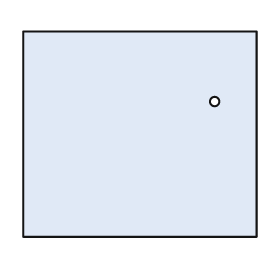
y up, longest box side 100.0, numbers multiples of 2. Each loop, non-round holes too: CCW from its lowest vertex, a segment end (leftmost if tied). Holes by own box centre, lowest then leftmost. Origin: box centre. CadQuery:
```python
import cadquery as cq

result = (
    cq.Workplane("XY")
    .moveTo(-50.0, -44.0)
    .lineTo(50.0, -44.0)
    .lineTo(50.0, 44.0)
    .lineTo(-50.0, 44.0)
    .close()
    .moveTo(32.0, 14.0)
    .circle(2.0)
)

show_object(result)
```